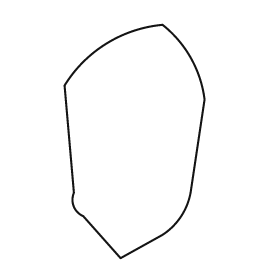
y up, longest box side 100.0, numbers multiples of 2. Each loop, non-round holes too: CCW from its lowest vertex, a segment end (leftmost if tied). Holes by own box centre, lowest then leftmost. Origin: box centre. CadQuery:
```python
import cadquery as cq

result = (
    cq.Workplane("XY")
    .moveTo(-6.0, -50.0)
    .lineTo(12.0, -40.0)
    .threePointArc((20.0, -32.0), (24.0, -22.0))
    .lineTo(30.0, 18.0)
    .threePointArc((24.0, 36.0), (12.0, 50.0))
    .threePointArc((-12.0, 42.0), (-30.0, 24.0))
    .lineTo(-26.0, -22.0)
    .threePointArc((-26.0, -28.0), (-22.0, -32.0))
    .close()
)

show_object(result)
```